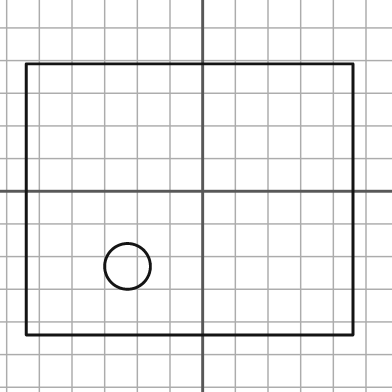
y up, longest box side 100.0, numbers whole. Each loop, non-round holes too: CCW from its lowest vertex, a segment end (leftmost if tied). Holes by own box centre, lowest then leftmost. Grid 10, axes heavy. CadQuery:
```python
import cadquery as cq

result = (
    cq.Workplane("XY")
    .moveTo(-54.0, -44.0)
    .lineTo(46.0, -44.0)
    .lineTo(46.0, 39.0)
    .lineTo(-54.0, 39.0)
    .close()
    .moveTo(-23.0, -23.0)
    .circle(7.0)
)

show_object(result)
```